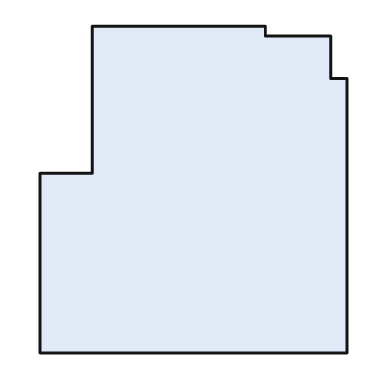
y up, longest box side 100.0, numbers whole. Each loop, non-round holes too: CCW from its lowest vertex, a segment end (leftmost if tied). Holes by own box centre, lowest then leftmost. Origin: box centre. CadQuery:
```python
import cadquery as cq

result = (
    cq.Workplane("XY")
    .moveTo(-47.0, -50.0)
    .lineTo(47.0, -50.0)
    .lineTo(47.0, 34.0)
    .lineTo(42.0, 34.0)
    .lineTo(42.0, 47.0)
    .lineTo(22.0, 47.0)
    .lineTo(22.0, 50.0)
    .lineTo(-31.0, 50.0)
    .lineTo(-31.0, 5.0)
    .lineTo(-47.0, 5.0)
    .close()
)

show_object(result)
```